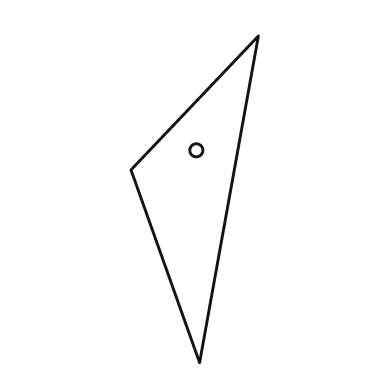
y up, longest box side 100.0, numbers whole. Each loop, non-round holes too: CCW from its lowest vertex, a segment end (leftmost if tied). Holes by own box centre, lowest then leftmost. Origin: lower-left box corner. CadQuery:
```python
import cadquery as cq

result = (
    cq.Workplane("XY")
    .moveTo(21.0, 0.0)
    .lineTo(39.0, 100.0)
    .lineTo(0.0, 59.0)
    .close()
    .moveTo(20.0, 65.0)
    .circle(2.0)
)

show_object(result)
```